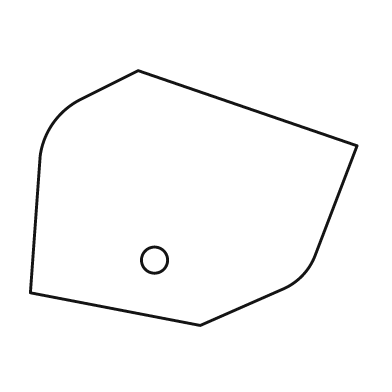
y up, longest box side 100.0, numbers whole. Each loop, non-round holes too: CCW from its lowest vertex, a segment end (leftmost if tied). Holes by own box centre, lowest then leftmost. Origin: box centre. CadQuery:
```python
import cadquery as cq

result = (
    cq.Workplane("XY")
    .moveTo(2.0, -39.0)
    .lineTo(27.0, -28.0)
    .threePointArc((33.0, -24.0), (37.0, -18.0))
    .lineTo(50.0, 16.0)
    .lineTo(-17.0, 39.0)
    .lineTo(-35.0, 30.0)
    .threePointArc((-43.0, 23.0), (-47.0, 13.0))
    .lineTo(-50.0, -29.0)
    .close()
    .moveTo(-12.0, -19.0)
    .circle(4.0)
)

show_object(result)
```